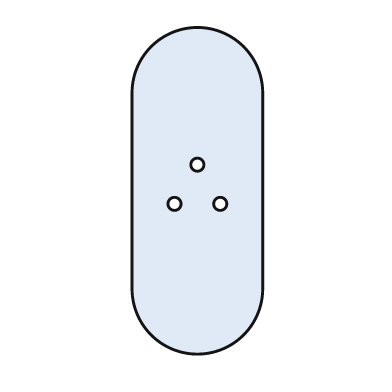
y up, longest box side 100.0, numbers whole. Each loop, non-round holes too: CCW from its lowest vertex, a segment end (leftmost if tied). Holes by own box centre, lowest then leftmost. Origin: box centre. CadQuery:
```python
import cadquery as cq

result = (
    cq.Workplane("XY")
    .moveTo(-20.0, -30.0)
    .threePointArc((0.0, -50.0), (20.0, -30.0))
    .lineTo(20.0, 30.0)
    .threePointArc((0.0, 50.0), (-20.0, 30.0))
    .close()
    .moveTo(-7.0, -4.0)
    .circle(2.0)
    .moveTo(7.0, -4.0)
    .circle(2.0)
    .moveTo(0.0, 8.0)
    .circle(2.0)
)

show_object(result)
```